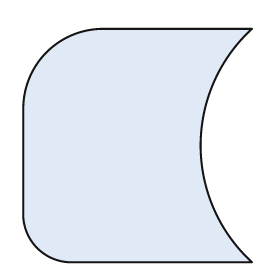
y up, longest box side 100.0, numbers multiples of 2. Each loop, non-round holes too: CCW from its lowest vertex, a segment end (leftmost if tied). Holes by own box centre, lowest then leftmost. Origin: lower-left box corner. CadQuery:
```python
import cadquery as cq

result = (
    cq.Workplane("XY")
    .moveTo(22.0, 0.0)
    .lineTo(98.0, 0.0)
    .threePointArc((76.0, 50.0), (98.0, 100.0))
    .lineTo(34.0, 100.0)
    .threePointArc((10.0, 90.0), (0.0, 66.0))
    .lineTo(0.0, 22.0)
    .threePointArc((6.0, 6.0), (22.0, 0.0))
    .close()
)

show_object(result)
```